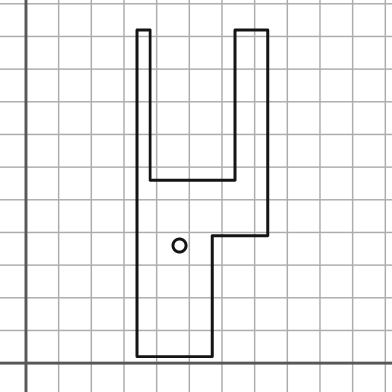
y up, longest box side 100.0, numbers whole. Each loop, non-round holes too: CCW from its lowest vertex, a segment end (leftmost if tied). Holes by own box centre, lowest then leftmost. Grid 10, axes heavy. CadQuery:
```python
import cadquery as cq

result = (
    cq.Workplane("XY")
    .moveTo(34.0, 2.0)
    .lineTo(57.0, 2.0)
    .lineTo(57.0, 39.0)
    .lineTo(74.0, 39.0)
    .lineTo(74.0, 102.0)
    .lineTo(64.0, 102.0)
    .lineTo(64.0, 56.0)
    .lineTo(38.0, 56.0)
    .lineTo(38.0, 102.0)
    .lineTo(34.0, 102.0)
    .close()
    .moveTo(47.0, 36.0)
    .circle(2.0)
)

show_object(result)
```